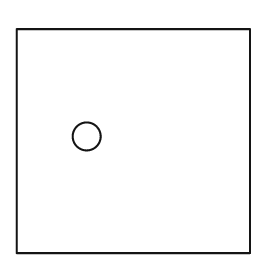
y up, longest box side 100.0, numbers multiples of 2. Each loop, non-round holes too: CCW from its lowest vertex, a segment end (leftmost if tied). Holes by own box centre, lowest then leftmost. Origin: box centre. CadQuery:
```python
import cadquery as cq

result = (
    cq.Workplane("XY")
    .moveTo(-50.0, -48.0)
    .lineTo(50.0, -48.0)
    .lineTo(50.0, 48.0)
    .lineTo(-50.0, 48.0)
    .close()
    .moveTo(-20.0, 2.0)
    .circle(6.0)
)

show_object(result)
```